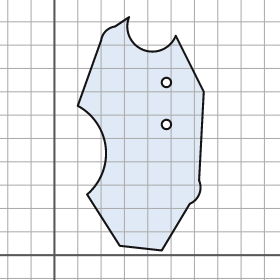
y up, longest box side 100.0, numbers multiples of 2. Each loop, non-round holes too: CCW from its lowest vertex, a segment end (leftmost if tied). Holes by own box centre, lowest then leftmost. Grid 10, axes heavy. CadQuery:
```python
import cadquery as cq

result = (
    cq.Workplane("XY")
    .moveTo(46.0, 2.0)
    .lineTo(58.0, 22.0)
    .threePointArc((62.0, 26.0), (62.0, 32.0))
    .lineTo(64.0, 70.0)
    .lineTo(52.0, 94.0)
    .threePointArc((38.0, 88.0), (32.0, 102.0))
    .lineTo(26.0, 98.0)
    .threePointArc((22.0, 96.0), (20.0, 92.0))
    .lineTo(10.0, 64.0)
    .threePointArc((22.0, 46.0), (14.0, 26.0))
    .lineTo(28.0, 4.0)
    .close()
    .moveTo(48.0, 56.0)
    .circle(2.0)
    .moveTo(48.0, 74.0)
    .circle(2.0)
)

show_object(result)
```